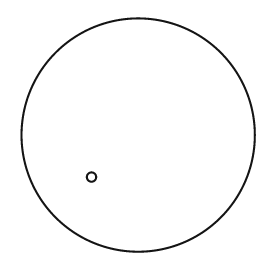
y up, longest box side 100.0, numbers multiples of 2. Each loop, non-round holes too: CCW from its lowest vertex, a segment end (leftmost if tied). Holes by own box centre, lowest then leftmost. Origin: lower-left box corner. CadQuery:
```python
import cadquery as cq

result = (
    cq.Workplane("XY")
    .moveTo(50.0, 50.0)
    .circle(50.0)
    .moveTo(30.0, 32.0)
    .circle(2.0)
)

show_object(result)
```